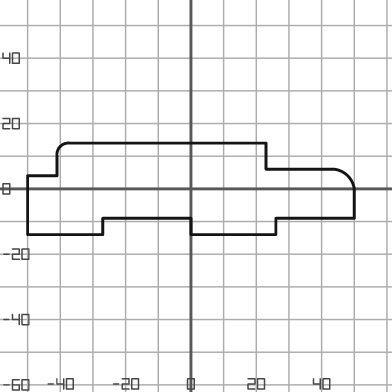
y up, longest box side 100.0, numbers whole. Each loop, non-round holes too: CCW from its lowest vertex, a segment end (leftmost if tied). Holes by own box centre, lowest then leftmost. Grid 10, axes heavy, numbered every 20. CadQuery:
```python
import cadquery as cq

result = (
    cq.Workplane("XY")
    .moveTo(-50.0, -14.0)
    .lineTo(-27.0, -14.0)
    .lineTo(-27.0, -9.0)
    .lineTo(0.0, -9.0)
    .lineTo(0.0, -14.0)
    .lineTo(26.0, -14.0)
    .lineTo(26.0, -9.0)
    .lineTo(50.0, -9.0)
    .lineTo(50.0, 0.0)
    .threePointArc((48.0, 4.0), (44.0, 6.0))
    .lineTo(23.0, 6.0)
    .lineTo(23.0, 14.0)
    .lineTo(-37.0, 14.0)
    .threePointArc((-40.0, 13.0), (-41.0, 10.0))
    .lineTo(-41.0, 4.0)
    .lineTo(-50.0, 4.0)
    .close()
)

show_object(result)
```